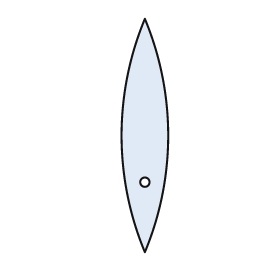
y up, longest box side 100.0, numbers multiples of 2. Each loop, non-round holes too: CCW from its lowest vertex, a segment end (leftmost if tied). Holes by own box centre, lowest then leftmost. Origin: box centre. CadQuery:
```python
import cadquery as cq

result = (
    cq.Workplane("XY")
    .moveTo(0.0, -50.0)
    .threePointArc((10.0, 0.0), (0.0, 50.0))
    .threePointArc((-10.0, 0.0), (0.0, -50.0))
    .close()
    .moveTo(0.0, -20.0)
    .circle(2.0)
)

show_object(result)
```